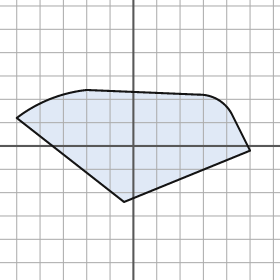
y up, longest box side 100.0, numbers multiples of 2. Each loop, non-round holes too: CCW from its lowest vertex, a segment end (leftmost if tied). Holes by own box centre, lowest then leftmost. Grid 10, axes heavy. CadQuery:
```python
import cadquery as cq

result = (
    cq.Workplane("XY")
    .moveTo(-4.0, -24.0)
    .lineTo(50.0, -2.0)
    .lineTo(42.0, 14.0)
    .threePointArc((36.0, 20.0), (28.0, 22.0))
    .lineTo(-20.0, 24.0)
    .threePointArc((-36.0, 20.0), (-50.0, 12.0))
    .close()
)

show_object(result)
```